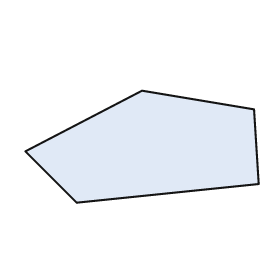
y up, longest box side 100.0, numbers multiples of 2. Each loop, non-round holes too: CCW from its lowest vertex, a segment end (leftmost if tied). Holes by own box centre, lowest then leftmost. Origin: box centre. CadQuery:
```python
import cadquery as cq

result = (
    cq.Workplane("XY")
    .moveTo(-28.0, -24.0)
    .lineTo(50.0, -16.0)
    .lineTo(48.0, 16.0)
    .lineTo(0.0, 24.0)
    .lineTo(-50.0, -2.0)
    .close()
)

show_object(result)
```